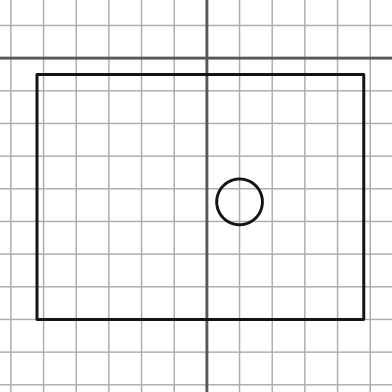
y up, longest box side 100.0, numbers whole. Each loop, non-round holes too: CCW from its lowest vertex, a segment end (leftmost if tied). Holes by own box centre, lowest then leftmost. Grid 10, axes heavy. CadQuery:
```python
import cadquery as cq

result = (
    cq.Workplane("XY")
    .moveTo(-52.0, -80.0)
    .lineTo(48.0, -80.0)
    .lineTo(48.0, -5.0)
    .lineTo(-52.0, -5.0)
    .close()
    .moveTo(10.0, -44.0)
    .circle(7.0)
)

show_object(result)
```